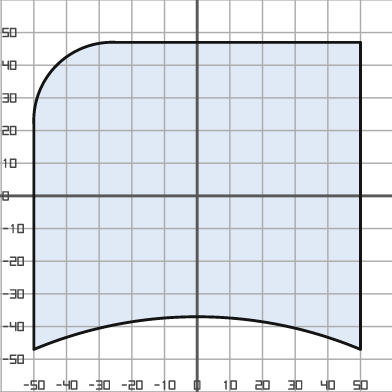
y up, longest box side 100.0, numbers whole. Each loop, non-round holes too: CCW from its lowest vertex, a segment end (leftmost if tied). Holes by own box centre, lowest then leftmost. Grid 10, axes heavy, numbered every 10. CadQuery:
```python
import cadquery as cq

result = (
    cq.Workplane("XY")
    .moveTo(-50.0, -47.0)
    .threePointArc((0.0, -37.0), (50.0, -47.0))
    .lineTo(50.0, 47.0)
    .lineTo(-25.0, 47.0)
    .threePointArc((-43.0, 40.0), (-50.0, 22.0))
    .close()
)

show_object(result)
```